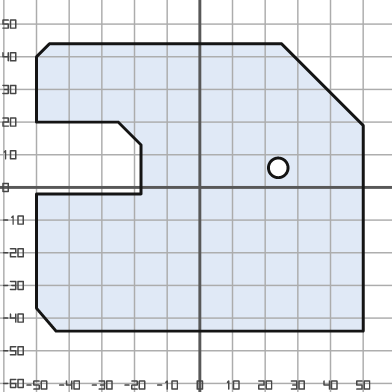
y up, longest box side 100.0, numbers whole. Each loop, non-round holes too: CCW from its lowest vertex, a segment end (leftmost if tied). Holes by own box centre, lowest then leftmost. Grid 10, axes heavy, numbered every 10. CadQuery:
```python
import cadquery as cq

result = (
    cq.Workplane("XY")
    .moveTo(-44.0, -44.0)
    .lineTo(50.0, -44.0)
    .lineTo(50.0, 19.0)
    .lineTo(25.0, 44.0)
    .lineTo(-46.0, 44.0)
    .lineTo(-50.0, 40.0)
    .lineTo(-50.0, 20.0)
    .lineTo(-25.0, 20.0)
    .lineTo(-18.0, 13.0)
    .lineTo(-18.0, -2.0)
    .lineTo(-50.0, -2.0)
    .lineTo(-50.0, -37.0)
    .close()
    .moveTo(24.0, 6.0)
    .circle(3.0)
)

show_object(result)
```